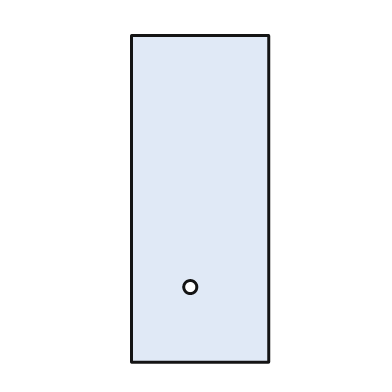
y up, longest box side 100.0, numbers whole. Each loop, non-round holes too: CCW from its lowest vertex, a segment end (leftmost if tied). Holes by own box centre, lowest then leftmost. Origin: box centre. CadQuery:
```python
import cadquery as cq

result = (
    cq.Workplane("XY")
    .moveTo(-21.0, -50.0)
    .lineTo(21.0, -50.0)
    .lineTo(21.0, 50.0)
    .lineTo(-21.0, 50.0)
    .close()
    .moveTo(-3.0, -27.0)
    .circle(2.0)
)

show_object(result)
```